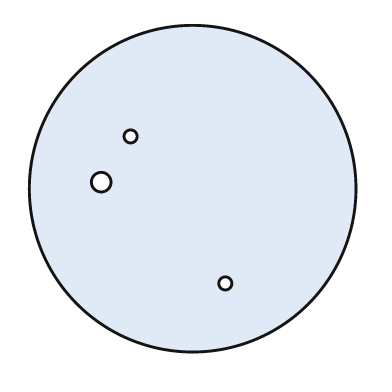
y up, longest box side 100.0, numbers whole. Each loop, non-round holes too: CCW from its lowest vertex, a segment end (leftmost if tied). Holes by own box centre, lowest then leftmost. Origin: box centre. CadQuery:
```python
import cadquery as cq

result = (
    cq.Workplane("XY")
    .moveTo(0.0, 0.0)
    .circle(50.0)
    .moveTo(10.0, -29.0)
    .circle(2.0)
    .moveTo(-28.0, 2.0)
    .circle(3.0)
    .moveTo(-19.0, 16.0)
    .circle(2.0)
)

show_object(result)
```